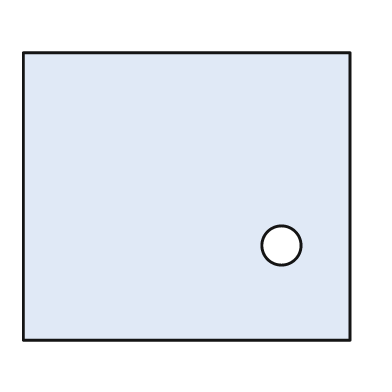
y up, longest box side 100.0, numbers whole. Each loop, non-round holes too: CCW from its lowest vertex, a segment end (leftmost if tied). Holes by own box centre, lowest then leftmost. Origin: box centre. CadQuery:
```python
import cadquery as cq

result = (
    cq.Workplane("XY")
    .moveTo(-50.0, -44.0)
    .lineTo(50.0, -44.0)
    .lineTo(50.0, 44.0)
    .lineTo(-50.0, 44.0)
    .close()
    .moveTo(29.0, -15.0)
    .circle(6.0)
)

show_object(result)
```